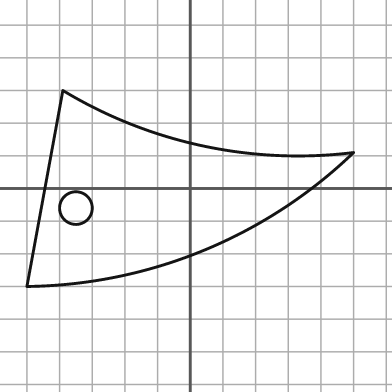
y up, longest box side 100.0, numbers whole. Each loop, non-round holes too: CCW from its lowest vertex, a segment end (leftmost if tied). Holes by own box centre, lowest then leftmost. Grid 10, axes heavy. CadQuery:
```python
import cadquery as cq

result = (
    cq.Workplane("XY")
    .moveTo(-50.0, -30.0)
    .threePointArc((4.0, -19.0), (50.0, 11.0))
    .threePointArc((4.0, 13.0), (-39.0, 30.0))
    .close()
    .moveTo(-35.0, -6.0)
    .circle(5.0)
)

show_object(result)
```